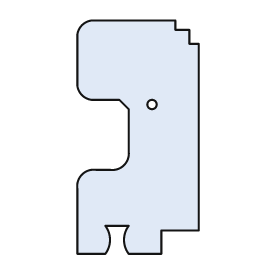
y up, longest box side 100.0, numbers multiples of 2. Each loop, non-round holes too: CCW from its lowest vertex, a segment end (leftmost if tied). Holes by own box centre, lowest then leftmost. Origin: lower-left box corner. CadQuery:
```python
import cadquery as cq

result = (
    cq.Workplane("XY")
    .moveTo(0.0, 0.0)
    .lineTo(12.0, 0.0)
    .threePointArc((14.0, 6.0), (12.0, 12.0))
    .lineTo(22.0, 12.0)
    .threePointArc((20.0, 6.0), (22.0, 0.0))
    .lineTo(36.0, 0.0)
    .lineTo(36.0, 10.0)
    .lineTo(52.0, 10.0)
    .lineTo(52.0, 90.0)
    .lineTo(48.0, 90.0)
    .lineTo(48.0, 96.0)
    .lineTo(42.0, 96.0)
    .lineTo(42.0, 100.0)
    .lineTo(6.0, 100.0)
    .threePointArc((2.0, 98.0), (0.0, 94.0))
    .lineTo(0.0, 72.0)
    .threePointArc((2.0, 68.0), (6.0, 66.0))
    .lineTo(18.0, 66.0)
    .lineTo(22.0, 62.0)
    .lineTo(22.0, 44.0)
    .threePointArc((20.0, 38.0), (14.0, 36.0))
    .lineTo(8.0, 36.0)
    .threePointArc((2.0, 34.0), (0.0, 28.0))
    .close()
    .moveTo(32.0, 64.0)
    .circle(2.0)
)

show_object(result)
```